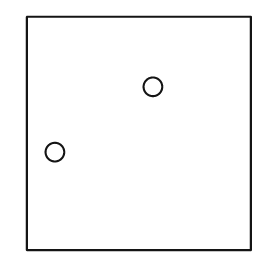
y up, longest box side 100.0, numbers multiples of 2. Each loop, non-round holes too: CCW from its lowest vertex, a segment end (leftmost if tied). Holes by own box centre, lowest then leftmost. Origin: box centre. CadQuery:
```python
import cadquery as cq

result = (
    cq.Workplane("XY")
    .moveTo(-48.0, -50.0)
    .lineTo(48.0, -50.0)
    .lineTo(48.0, 50.0)
    .lineTo(-48.0, 50.0)
    .close()
    .moveTo(-36.0, -8.0)
    .circle(4.0)
    .moveTo(6.0, 20.0)
    .circle(4.0)
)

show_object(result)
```